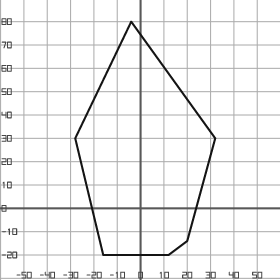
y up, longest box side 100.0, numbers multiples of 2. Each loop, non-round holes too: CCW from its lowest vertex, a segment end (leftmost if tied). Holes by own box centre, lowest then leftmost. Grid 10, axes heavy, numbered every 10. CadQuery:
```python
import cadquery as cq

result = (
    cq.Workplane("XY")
    .moveTo(-16.0, -20.0)
    .lineTo(12.0, -20.0)
    .lineTo(20.0, -14.0)
    .lineTo(32.0, 30.0)
    .lineTo(-4.0, 80.0)
    .lineTo(-28.0, 30.0)
    .close()
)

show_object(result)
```